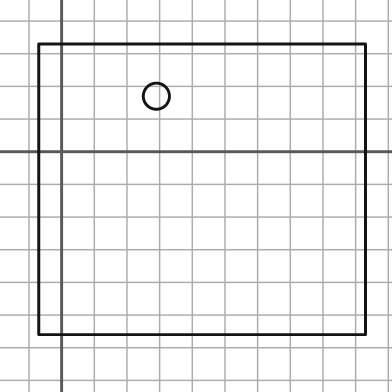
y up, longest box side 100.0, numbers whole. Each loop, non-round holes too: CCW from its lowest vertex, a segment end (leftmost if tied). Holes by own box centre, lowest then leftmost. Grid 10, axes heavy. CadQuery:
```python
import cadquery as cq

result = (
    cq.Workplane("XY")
    .moveTo(-7.0, -56.0)
    .lineTo(93.0, -56.0)
    .lineTo(93.0, 33.0)
    .lineTo(-7.0, 33.0)
    .close()
    .moveTo(29.0, 17.0)
    .circle(4.0)
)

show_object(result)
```